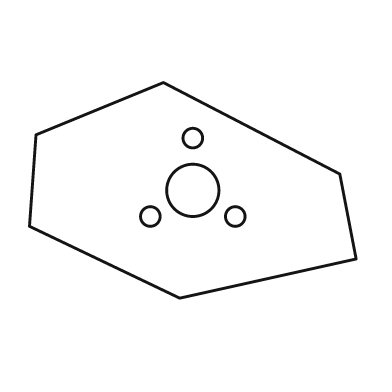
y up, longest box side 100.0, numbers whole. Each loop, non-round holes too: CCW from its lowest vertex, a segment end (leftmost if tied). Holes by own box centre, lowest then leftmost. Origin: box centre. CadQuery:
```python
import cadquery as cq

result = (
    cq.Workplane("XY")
    .moveTo(-4.0, -33.0)
    .lineTo(50.0, -21.0)
    .lineTo(45.0, 5.0)
    .lineTo(-9.0, 33.0)
    .lineTo(-48.0, 17.0)
    .lineTo(-50.0, -11.0)
    .close()
    .moveTo(-13.0, -8.0)
    .circle(3.0)
    .moveTo(13.0, -8.0)
    .circle(3.0)
    .moveTo(0.0, 0.0)
    .circle(8.0)
    .moveTo(0.0, 16.0)
    .circle(3.0)
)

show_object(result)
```